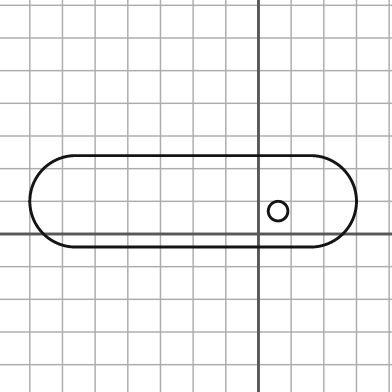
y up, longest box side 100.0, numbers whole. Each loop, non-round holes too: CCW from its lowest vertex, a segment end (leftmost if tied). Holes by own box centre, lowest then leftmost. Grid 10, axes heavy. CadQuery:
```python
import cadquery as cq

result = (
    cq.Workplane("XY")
    .moveTo(-56.0, -4.0)
    .lineTo(16.0, -4.0)
    .threePointArc((30.0, 10.0), (16.0, 24.0))
    .lineTo(-56.0, 24.0)
    .threePointArc((-70.0, 10.0), (-56.0, -4.0))
    .close()
    .moveTo(6.0, 7.0)
    .circle(3.0)
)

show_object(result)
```